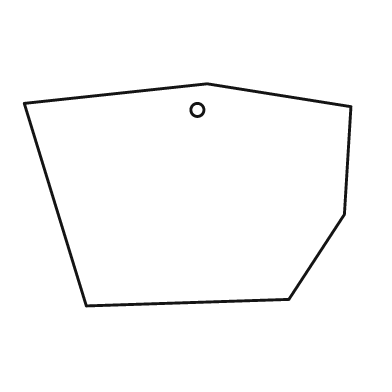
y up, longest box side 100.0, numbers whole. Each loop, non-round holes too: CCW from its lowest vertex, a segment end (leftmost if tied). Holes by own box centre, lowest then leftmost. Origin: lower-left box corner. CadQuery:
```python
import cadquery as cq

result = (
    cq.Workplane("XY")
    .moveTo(19.0, 0.0)
    .lineTo(81.0, 2.0)
    .lineTo(98.0, 28.0)
    .lineTo(100.0, 61.0)
    .lineTo(56.0, 68.0)
    .lineTo(0.0, 62.0)
    .close()
    .moveTo(53.0, 60.0)
    .circle(2.0)
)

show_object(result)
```